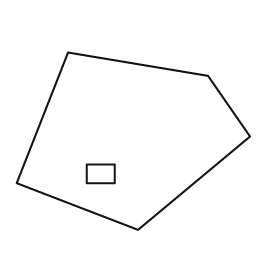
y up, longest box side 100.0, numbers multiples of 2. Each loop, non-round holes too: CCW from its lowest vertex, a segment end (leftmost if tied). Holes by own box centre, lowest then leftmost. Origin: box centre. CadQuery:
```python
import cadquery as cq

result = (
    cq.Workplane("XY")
    .moveTo(2.0, -38.0)
    .lineTo(50.0, 2.0)
    .lineTo(32.0, 28.0)
    .lineTo(-28.0, 38.0)
    .lineTo(-50.0, -18.0)
    .close()
    .moveTo(-20.0, -18.0)
    .lineTo(-8.0, -18.0)
    .lineTo(-8.0, -10.0)
    .lineTo(-20.0, -10.0)
    .close()
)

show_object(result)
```